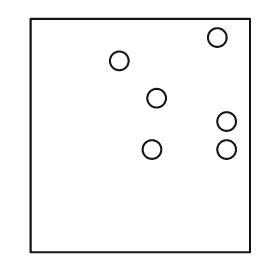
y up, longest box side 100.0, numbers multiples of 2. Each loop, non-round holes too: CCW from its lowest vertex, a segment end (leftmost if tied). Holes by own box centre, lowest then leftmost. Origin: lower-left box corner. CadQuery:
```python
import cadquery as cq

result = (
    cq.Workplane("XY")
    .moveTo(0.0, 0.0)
    .lineTo(94.0, 0.0)
    .lineTo(94.0, 100.0)
    .lineTo(0.0, 100.0)
    .close()
    .moveTo(52.0, 44.0)
    .circle(4.0)
    .moveTo(84.0, 44.0)
    .circle(4.0)
    .moveTo(84.0, 56.0)
    .circle(4.0)
    .moveTo(54.0, 66.0)
    .circle(4.0)
    .moveTo(38.0, 82.0)
    .circle(4.0)
    .moveTo(80.0, 92.0)
    .circle(4.0)
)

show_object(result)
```